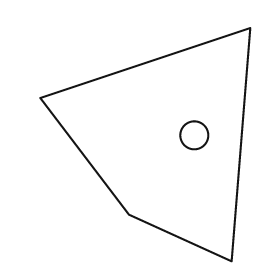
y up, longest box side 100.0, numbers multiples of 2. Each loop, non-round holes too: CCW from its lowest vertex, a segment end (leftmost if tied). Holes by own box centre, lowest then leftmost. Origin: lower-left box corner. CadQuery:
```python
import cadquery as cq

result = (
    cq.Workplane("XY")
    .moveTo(82.0, 0.0)
    .lineTo(90.0, 100.0)
    .lineTo(0.0, 70.0)
    .lineTo(38.0, 20.0)
    .close()
    .moveTo(66.0, 54.0)
    .circle(6.0)
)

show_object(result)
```